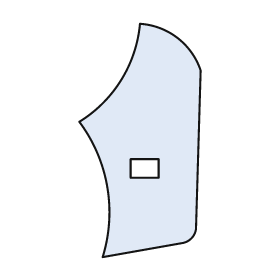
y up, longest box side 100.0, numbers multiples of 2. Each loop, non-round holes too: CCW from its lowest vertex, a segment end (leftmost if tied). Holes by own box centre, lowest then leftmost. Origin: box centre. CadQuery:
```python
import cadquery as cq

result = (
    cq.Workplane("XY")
    .moveTo(-16.0, -50.0)
    .lineTo(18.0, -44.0)
    .threePointArc((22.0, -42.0), (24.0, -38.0))
    .lineTo(26.0, 30.0)
    .threePointArc((16.0, 44.0), (0.0, 50.0))
    .threePointArc((-8.0, 26.0), (-26.0, 8.0))
    .threePointArc((-14.0, -20.0), (-16.0, -50.0))
    .close()
    .moveTo(-4.0, -16.0)
    .lineTo(8.0, -16.0)
    .lineTo(8.0, -8.0)
    .lineTo(-4.0, -8.0)
    .close()
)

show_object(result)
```